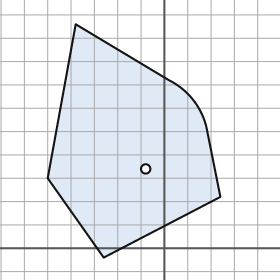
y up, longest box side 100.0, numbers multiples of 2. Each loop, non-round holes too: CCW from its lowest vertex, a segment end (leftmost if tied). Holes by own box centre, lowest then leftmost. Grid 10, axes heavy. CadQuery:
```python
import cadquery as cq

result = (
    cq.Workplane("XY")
    .moveTo(-26.0, -4.0)
    .lineTo(24.0, 22.0)
    .lineTo(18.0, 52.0)
    .threePointArc((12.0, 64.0), (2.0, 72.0))
    .lineTo(-38.0, 96.0)
    .lineTo(-50.0, 30.0)
    .close()
    .moveTo(-8.0, 34.0)
    .circle(2.0)
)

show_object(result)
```